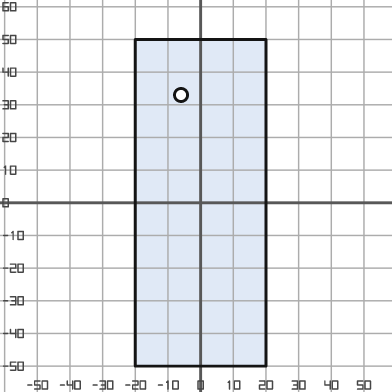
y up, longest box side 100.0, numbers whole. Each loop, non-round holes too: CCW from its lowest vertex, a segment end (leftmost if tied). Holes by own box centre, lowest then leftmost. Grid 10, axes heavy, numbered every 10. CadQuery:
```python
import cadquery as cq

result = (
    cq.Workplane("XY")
    .moveTo(-20.0, -50.0)
    .lineTo(20.0, -50.0)
    .lineTo(20.0, 50.0)
    .lineTo(-20.0, 50.0)
    .close()
    .moveTo(-6.0, 33.0)
    .circle(2.0)
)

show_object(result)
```